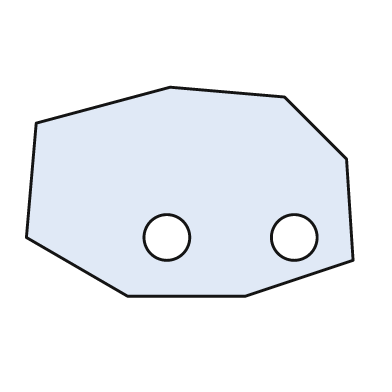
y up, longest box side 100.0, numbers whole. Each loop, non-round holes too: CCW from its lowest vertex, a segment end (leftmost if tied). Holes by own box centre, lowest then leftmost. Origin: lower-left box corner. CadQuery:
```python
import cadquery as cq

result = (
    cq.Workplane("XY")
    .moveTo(31.0, 0.0)
    .lineTo(67.0, 0.0)
    .lineTo(100.0, 11.0)
    .lineTo(98.0, 42.0)
    .lineTo(79.0, 61.0)
    .lineTo(44.0, 64.0)
    .lineTo(3.0, 53.0)
    .lineTo(0.0, 18.0)
    .close()
    .moveTo(43.0, 18.0)
    .circle(7.0)
    .moveTo(82.0, 18.0)
    .circle(7.0)
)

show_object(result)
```